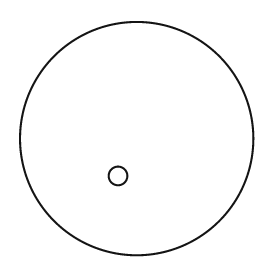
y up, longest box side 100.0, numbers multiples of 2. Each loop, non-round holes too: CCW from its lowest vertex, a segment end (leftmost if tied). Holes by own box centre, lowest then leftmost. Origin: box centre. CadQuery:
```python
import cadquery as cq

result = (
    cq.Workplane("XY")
    .moveTo(0.0, 0.0)
    .circle(50.0)
    .moveTo(-8.0, -16.0)
    .circle(4.0)
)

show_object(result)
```